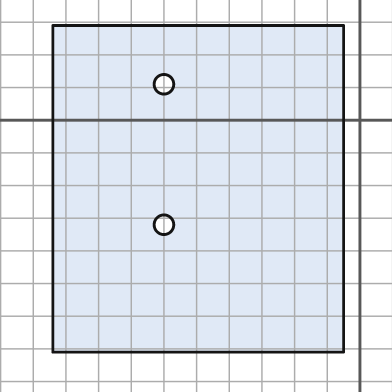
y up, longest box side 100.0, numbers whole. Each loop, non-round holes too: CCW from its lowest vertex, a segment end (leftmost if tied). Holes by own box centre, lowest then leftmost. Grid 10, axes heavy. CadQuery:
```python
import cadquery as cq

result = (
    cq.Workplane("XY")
    .moveTo(-94.0, -71.0)
    .lineTo(-5.0, -71.0)
    .lineTo(-5.0, 29.0)
    .lineTo(-94.0, 29.0)
    .close()
    .moveTo(-60.0, -32.0)
    .circle(3.0)
    .moveTo(-60.0, 11.0)
    .circle(3.0)
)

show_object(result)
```